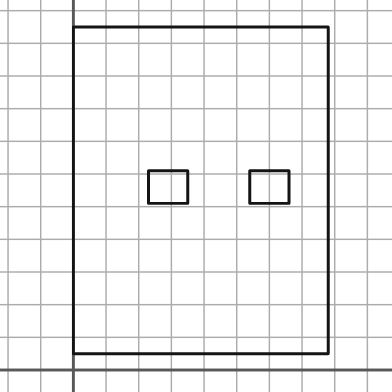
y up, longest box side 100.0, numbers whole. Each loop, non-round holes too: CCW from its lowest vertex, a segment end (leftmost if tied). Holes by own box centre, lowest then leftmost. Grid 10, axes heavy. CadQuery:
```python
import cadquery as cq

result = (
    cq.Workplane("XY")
    .moveTo(0.0, 5.0)
    .lineTo(78.0, 5.0)
    .lineTo(78.0, 105.0)
    .lineTo(0.0, 105.0)
    .close()
    .moveTo(23.0, 51.0)
    .lineTo(35.0, 51.0)
    .lineTo(35.0, 61.0)
    .lineTo(23.0, 61.0)
    .close()
    .moveTo(54.0, 51.0)
    .lineTo(66.0, 51.0)
    .lineTo(66.0, 61.0)
    .lineTo(54.0, 61.0)
    .close()
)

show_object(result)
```